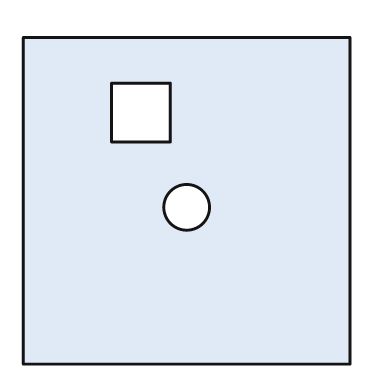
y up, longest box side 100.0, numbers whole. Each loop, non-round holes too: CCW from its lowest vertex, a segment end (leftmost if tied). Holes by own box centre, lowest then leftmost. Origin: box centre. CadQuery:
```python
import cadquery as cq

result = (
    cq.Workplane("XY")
    .moveTo(-50.0, -50.0)
    .lineTo(50.0, -50.0)
    .lineTo(50.0, 50.0)
    .lineTo(-50.0, 50.0)
    .close()
    .moveTo(0.0, -2.0)
    .circle(7.0)
    .moveTo(-23.0, 18.0)
    .lineTo(-5.0, 18.0)
    .lineTo(-5.0, 36.0)
    .lineTo(-23.0, 36.0)
    .close()
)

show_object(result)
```